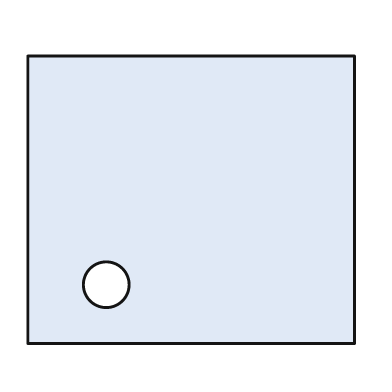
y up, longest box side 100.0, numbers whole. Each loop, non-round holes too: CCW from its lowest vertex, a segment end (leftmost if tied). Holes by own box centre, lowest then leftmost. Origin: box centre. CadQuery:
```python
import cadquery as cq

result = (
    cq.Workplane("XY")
    .moveTo(-50.0, -44.0)
    .lineTo(50.0, -44.0)
    .lineTo(50.0, 44.0)
    .lineTo(-50.0, 44.0)
    .close()
    .moveTo(-26.0, -26.0)
    .circle(7.0)
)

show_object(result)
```